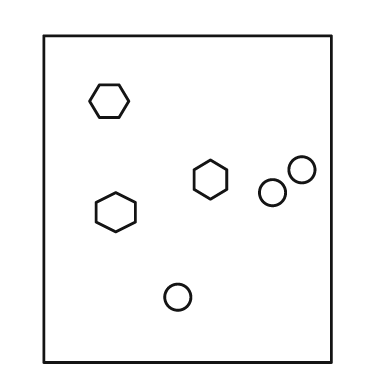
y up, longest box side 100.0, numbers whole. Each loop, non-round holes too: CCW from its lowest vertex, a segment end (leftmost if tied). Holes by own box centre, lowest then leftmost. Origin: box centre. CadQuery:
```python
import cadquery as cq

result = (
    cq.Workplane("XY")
    .moveTo(-44.0, -50.0)
    .lineTo(44.0, -50.0)
    .lineTo(44.0, 50.0)
    .lineTo(-44.0, 50.0)
    .close()
    .moveTo(-3.0, -30.0)
    .circle(4.0)
    .moveTo(-22.0, -10.0)
    .lineTo(-16.0, -7.0)
    .lineTo(-16.0, -1.0)
    .lineTo(-22.0, 2.0)
    .lineTo(-28.0, -1.0)
    .lineTo(-28.0, -7.0)
    .close()
    .moveTo(26.0, 2.0)
    .circle(4.0)
    .moveTo(7.0, 0.0)
    .lineTo(12.0, 3.0)
    .lineTo(12.0, 9.0)
    .lineTo(7.0, 12.0)
    .lineTo(2.0, 9.0)
    .lineTo(2.0, 3.0)
    .close()
    .moveTo(35.0, 9.0)
    .circle(4.0)
    .moveTo(-27.0, 25.0)
    .lineTo(-21.0, 25.0)
    .lineTo(-18.0, 30.0)
    .lineTo(-21.0, 35.0)
    .lineTo(-27.0, 35.0)
    .lineTo(-30.0, 30.0)
    .close()
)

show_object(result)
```